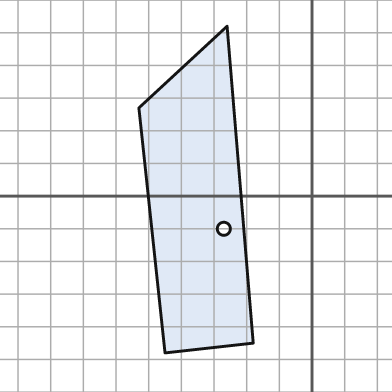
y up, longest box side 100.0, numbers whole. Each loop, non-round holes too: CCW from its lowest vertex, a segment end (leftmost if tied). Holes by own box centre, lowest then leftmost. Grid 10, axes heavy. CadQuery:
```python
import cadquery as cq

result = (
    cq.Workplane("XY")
    .moveTo(-45.0, -48.0)
    .lineTo(-18.0, -45.0)
    .lineTo(-26.0, 52.0)
    .lineTo(-53.0, 27.0)
    .close()
    .moveTo(-27.0, -10.0)
    .circle(2.0)
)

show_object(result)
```